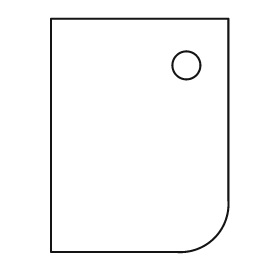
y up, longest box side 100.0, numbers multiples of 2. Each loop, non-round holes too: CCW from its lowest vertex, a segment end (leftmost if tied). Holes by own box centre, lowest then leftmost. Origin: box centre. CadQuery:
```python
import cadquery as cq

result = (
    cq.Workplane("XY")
    .moveTo(-38.0, -50.0)
    .lineTo(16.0, -50.0)
    .threePointArc((32.0, -44.0), (38.0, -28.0))
    .lineTo(38.0, 50.0)
    .lineTo(-38.0, 50.0)
    .close()
    .moveTo(20.0, 30.0)
    .circle(6.0)
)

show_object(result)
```